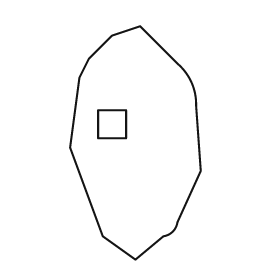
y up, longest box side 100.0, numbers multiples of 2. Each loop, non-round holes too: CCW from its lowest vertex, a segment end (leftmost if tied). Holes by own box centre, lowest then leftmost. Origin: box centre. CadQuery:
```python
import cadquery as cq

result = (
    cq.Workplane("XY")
    .moveTo(0.0, -50.0)
    .lineTo(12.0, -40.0)
    .threePointArc((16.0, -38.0), (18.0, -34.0))
    .lineTo(28.0, -12.0)
    .lineTo(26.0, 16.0)
    .threePointArc((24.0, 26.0), (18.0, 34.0))
    .lineTo(2.0, 50.0)
    .lineTo(-10.0, 46.0)
    .lineTo(-20.0, 36.0)
    .lineTo(-24.0, 28.0)
    .lineTo(-28.0, -2.0)
    .lineTo(-14.0, -40.0)
    .close()
    .moveTo(-16.0, 2.0)
    .lineTo(-4.0, 2.0)
    .lineTo(-4.0, 14.0)
    .lineTo(-16.0, 14.0)
    .close()
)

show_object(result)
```